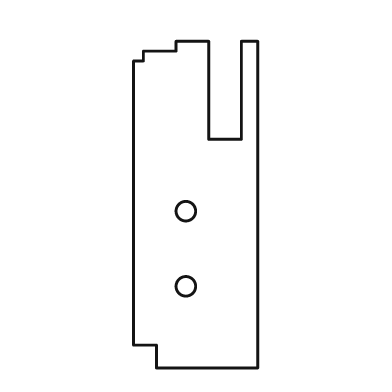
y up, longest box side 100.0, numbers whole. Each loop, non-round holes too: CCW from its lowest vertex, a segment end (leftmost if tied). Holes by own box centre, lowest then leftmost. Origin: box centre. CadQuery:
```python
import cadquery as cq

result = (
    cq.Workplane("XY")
    .moveTo(-12.0, -50.0)
    .lineTo(19.0, -50.0)
    .lineTo(19.0, 50.0)
    .lineTo(14.0, 50.0)
    .lineTo(14.0, 20.0)
    .lineTo(4.0, 20.0)
    .lineTo(4.0, 50.0)
    .lineTo(-6.0, 50.0)
    .lineTo(-6.0, 47.0)
    .lineTo(-16.0, 47.0)
    .lineTo(-16.0, 44.0)
    .lineTo(-19.0, 44.0)
    .lineTo(-19.0, -43.0)
    .lineTo(-12.0, -43.0)
    .close()
    .moveTo(-3.0, -25.0)
    .circle(3.0)
    .moveTo(-3.0, -2.0)
    .circle(3.0)
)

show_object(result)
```